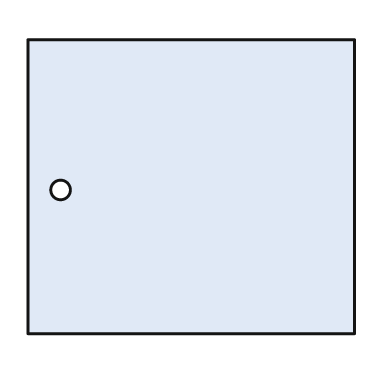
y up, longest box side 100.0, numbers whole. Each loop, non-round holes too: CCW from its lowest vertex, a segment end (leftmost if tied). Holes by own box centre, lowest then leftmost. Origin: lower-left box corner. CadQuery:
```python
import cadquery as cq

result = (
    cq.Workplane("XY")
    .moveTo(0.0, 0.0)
    .lineTo(100.0, 0.0)
    .lineTo(100.0, 90.0)
    .lineTo(0.0, 90.0)
    .close()
    .moveTo(10.0, 44.0)
    .circle(3.0)
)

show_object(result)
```